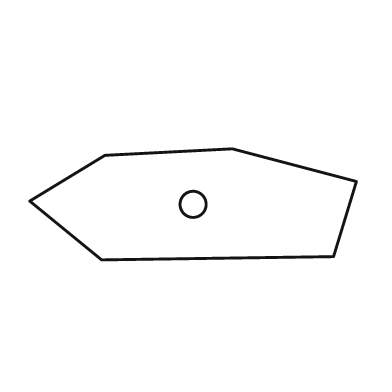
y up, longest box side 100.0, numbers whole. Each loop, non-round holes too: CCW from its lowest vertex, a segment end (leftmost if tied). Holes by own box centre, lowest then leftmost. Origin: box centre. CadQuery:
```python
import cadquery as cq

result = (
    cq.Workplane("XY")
    .moveTo(-28.0, -17.0)
    .lineTo(43.0, -16.0)
    .lineTo(50.0, 7.0)
    .lineTo(12.0, 17.0)
    .lineTo(-27.0, 15.0)
    .lineTo(-50.0, 1.0)
    .close()
    .moveTo(0.0, 0.0)
    .circle(4.0)
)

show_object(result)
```